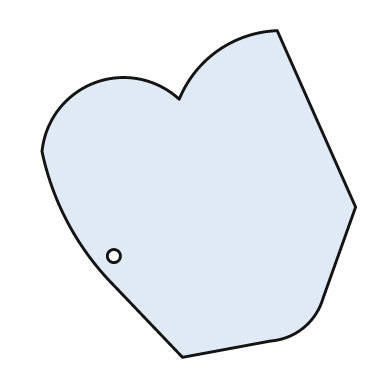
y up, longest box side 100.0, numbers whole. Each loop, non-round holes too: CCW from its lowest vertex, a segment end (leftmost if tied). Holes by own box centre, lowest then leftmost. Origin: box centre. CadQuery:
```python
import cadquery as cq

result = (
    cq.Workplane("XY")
    .moveTo(-5.0, -50.0)
    .lineTo(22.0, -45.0)
    .threePointArc((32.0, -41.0), (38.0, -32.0))
    .lineTo(48.0, -4.0)
    .lineTo(24.0, 50.0)
    .threePointArc((6.0, 44.0), (-6.0, 29.0))
    .threePointArc((-32.0, 34.0), (-48.0, 13.0))
    .threePointArc((-40.0, -9.0), (-26.0, -28.0))
    .close()
    .moveTo(-26.0, -19.0)
    .circle(2.0)
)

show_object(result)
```